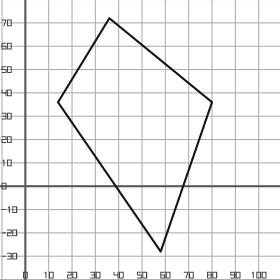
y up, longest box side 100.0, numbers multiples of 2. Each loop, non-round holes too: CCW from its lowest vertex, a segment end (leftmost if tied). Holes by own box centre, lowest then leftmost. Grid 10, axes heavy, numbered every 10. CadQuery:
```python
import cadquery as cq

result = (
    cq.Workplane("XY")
    .moveTo(58.0, -28.0)
    .lineTo(80.0, 36.0)
    .lineTo(36.0, 72.0)
    .lineTo(14.0, 36.0)
    .close()
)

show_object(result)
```